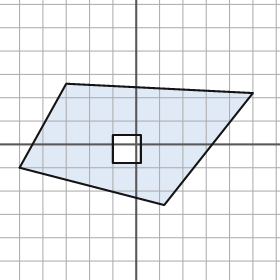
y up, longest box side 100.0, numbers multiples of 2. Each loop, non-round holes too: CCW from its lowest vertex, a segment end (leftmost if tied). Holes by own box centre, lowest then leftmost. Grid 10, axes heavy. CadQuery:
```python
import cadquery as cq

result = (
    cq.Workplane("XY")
    .moveTo(12.0, -26.0)
    .lineTo(50.0, 22.0)
    .lineTo(-30.0, 26.0)
    .lineTo(-50.0, -10.0)
    .close()
    .moveTo(-10.0, -8.0)
    .lineTo(2.0, -8.0)
    .lineTo(2.0, 4.0)
    .lineTo(-10.0, 4.0)
    .close()
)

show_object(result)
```